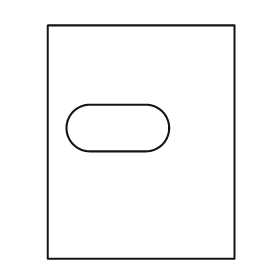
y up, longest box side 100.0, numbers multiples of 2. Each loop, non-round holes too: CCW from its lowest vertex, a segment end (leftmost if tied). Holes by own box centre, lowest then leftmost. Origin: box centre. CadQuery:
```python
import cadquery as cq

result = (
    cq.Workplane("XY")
    .moveTo(-40.0, -50.0)
    .lineTo(40.0, -50.0)
    .lineTo(40.0, 50.0)
    .lineTo(-40.0, 50.0)
    .close()
    .moveTo(-22.0, -4.0)
    .lineTo(2.0, -4.0)
    .threePointArc((12.0, 6.0), (2.0, 16.0))
    .lineTo(-22.0, 16.0)
    .threePointArc((-32.0, 6.0), (-22.0, -4.0))
    .close()
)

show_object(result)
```